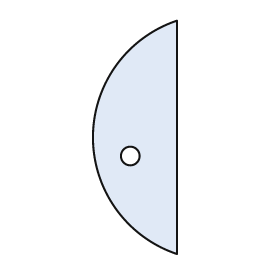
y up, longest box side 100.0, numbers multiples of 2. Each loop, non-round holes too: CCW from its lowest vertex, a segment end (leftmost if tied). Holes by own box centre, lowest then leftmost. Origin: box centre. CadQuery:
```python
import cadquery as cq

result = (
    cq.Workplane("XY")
    .moveTo(18.0, -50.0)
    .lineTo(18.0, 50.0)
    .threePointArc((-18.0, 0.0), (18.0, -50.0))
    .close()
    .moveTo(-2.0, -8.0)
    .circle(4.0)
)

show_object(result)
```